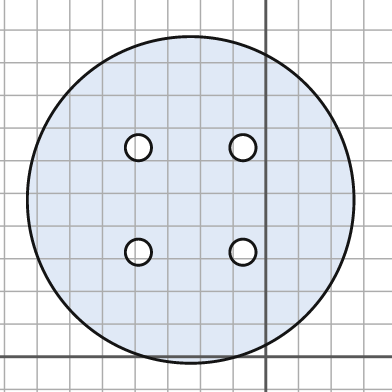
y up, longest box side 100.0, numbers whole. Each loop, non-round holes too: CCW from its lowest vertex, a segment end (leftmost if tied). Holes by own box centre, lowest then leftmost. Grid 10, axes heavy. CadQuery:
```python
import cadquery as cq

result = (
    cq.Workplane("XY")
    .moveTo(-23.0, 48.0)
    .circle(50.0)
    .moveTo(-39.0, 32.0)
    .circle(4.0)
    .moveTo(-7.0, 32.0)
    .circle(4.0)
    .moveTo(-39.0, 64.0)
    .circle(4.0)
    .moveTo(-7.0, 64.0)
    .circle(4.0)
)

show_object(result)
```